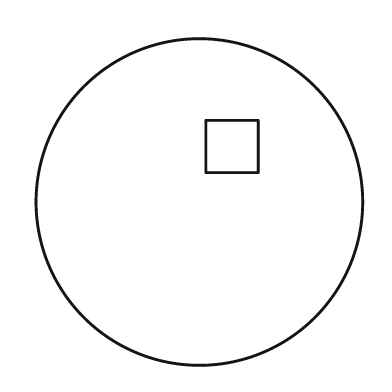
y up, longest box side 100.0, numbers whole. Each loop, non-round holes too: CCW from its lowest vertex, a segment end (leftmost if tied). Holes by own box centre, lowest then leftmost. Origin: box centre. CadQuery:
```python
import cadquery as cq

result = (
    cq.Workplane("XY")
    .moveTo(0.0, 0.0)
    .circle(50.0)
    .moveTo(2.0, 9.0)
    .lineTo(18.0, 9.0)
    .lineTo(18.0, 25.0)
    .lineTo(2.0, 25.0)
    .close()
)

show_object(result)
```